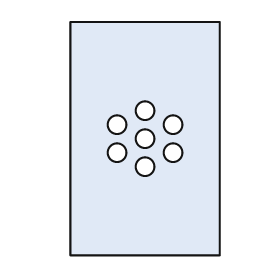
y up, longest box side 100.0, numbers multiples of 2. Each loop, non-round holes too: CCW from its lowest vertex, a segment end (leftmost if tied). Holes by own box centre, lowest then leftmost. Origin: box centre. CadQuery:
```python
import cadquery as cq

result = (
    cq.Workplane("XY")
    .moveTo(-32.0, -50.0)
    .lineTo(32.0, -50.0)
    .lineTo(32.0, 50.0)
    .lineTo(-32.0, 50.0)
    .close()
    .moveTo(0.0, -12.0)
    .circle(4.0)
    .moveTo(-12.0, -6.0)
    .circle(4.0)
    .moveTo(12.0, -6.0)
    .circle(4.0)
    .moveTo(0.0, 0.0)
    .circle(4.0)
    .moveTo(-12.0, 6.0)
    .circle(4.0)
    .moveTo(12.0, 6.0)
    .circle(4.0)
    .moveTo(0.0, 12.0)
    .circle(4.0)
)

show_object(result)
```